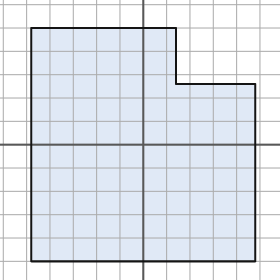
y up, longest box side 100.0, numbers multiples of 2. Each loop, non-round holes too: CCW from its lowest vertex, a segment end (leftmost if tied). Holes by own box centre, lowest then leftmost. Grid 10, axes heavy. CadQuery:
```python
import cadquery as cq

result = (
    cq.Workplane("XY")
    .moveTo(-48.0, -50.0)
    .lineTo(48.0, -50.0)
    .lineTo(48.0, 26.0)
    .lineTo(14.0, 26.0)
    .lineTo(14.0, 50.0)
    .lineTo(-48.0, 50.0)
    .close()
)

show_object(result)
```